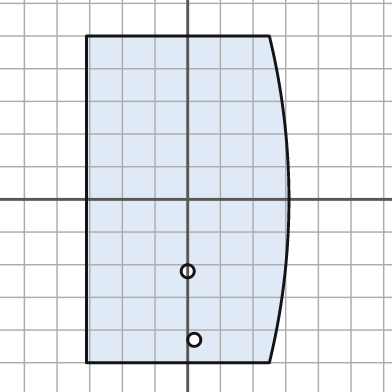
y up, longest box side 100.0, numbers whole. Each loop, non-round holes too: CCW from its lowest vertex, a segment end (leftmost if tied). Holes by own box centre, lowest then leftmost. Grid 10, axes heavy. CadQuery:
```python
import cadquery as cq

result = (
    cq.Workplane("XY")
    .moveTo(-31.0, -50.0)
    .lineTo(25.0, -50.0)
    .threePointArc((31.0, 0.0), (25.0, 50.0))
    .lineTo(-31.0, 50.0)
    .close()
    .moveTo(2.0, -43.0)
    .circle(2.0)
    .moveTo(0.0, -22.0)
    .circle(2.0)
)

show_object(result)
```